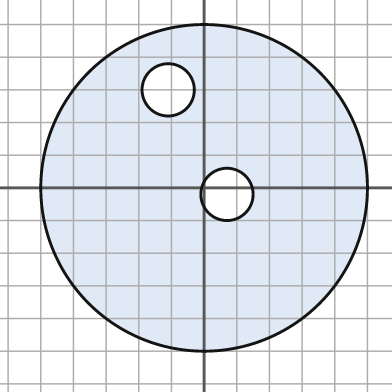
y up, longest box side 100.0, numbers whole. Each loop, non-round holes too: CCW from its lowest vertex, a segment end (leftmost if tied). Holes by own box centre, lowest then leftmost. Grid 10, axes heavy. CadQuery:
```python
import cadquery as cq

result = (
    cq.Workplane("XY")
    .moveTo(0.0, 0.0)
    .circle(50.0)
    .moveTo(7.0, -2.0)
    .circle(8.0)
    .moveTo(-11.0, 30.0)
    .circle(8.0)
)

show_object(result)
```